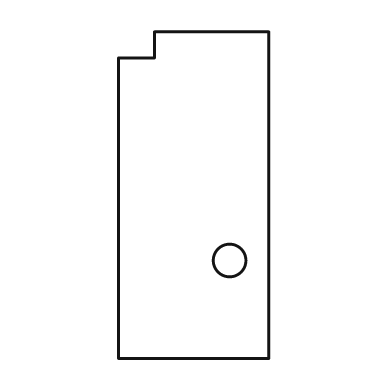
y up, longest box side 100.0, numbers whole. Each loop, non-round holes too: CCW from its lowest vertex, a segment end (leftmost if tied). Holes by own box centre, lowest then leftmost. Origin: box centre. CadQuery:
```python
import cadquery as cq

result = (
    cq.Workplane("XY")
    .moveTo(-23.0, -50.0)
    .lineTo(23.0, -50.0)
    .lineTo(23.0, 50.0)
    .lineTo(-12.0, 50.0)
    .lineTo(-12.0, 42.0)
    .lineTo(-23.0, 42.0)
    .close()
    .moveTo(11.0, -20.0)
    .circle(5.0)
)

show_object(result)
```